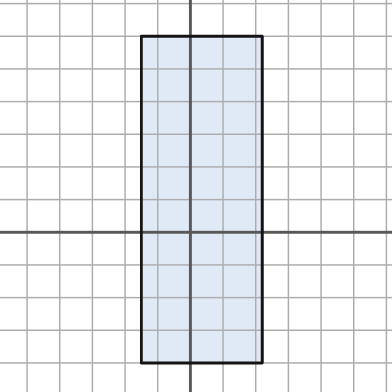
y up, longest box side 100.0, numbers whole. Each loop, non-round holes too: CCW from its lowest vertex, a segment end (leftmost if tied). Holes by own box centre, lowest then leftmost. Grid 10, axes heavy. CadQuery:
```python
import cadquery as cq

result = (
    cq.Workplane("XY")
    .moveTo(-15.0, -40.0)
    .lineTo(22.0, -40.0)
    .lineTo(22.0, 60.0)
    .lineTo(-15.0, 60.0)
    .close()
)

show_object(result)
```